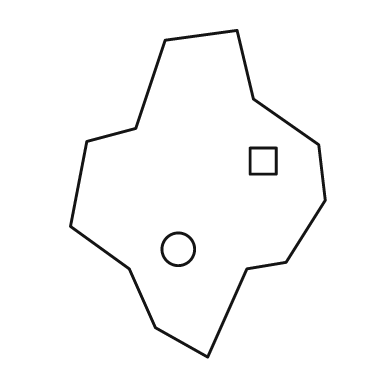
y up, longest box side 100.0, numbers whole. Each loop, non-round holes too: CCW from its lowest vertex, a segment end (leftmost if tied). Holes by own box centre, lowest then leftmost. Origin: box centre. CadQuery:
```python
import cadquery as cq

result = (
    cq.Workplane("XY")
    .moveTo(3.0, -50.0)
    .lineTo(15.0, -23.0)
    .lineTo(27.0, -21.0)
    .lineTo(39.0, -2.0)
    .lineTo(37.0, 15.0)
    .lineTo(17.0, 29.0)
    .lineTo(12.0, 50.0)
    .lineTo(-10.0, 47.0)
    .lineTo(-19.0, 20.0)
    .lineTo(-34.0, 16.0)
    .lineTo(-39.0, -10.0)
    .lineTo(-21.0, -23.0)
    .lineTo(-13.0, -41.0)
    .close()
    .moveTo(-6.0, -17.0)
    .circle(5.0)
    .moveTo(16.0, 6.0)
    .lineTo(24.0, 6.0)
    .lineTo(24.0, 14.0)
    .lineTo(16.0, 14.0)
    .close()
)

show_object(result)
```